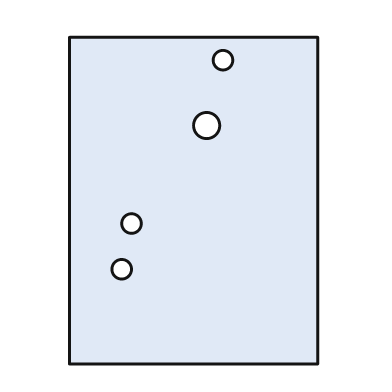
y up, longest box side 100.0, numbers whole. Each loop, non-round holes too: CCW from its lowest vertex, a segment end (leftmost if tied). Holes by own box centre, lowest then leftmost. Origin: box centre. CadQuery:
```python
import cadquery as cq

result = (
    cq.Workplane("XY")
    .moveTo(-38.0, -50.0)
    .lineTo(38.0, -50.0)
    .lineTo(38.0, 50.0)
    .lineTo(-38.0, 50.0)
    .close()
    .moveTo(-22.0, -21.0)
    .circle(3.0)
    .moveTo(-19.0, -7.0)
    .circle(3.0)
    .moveTo(4.0, 23.0)
    .circle(4.0)
    .moveTo(9.0, 43.0)
    .circle(3.0)
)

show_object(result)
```